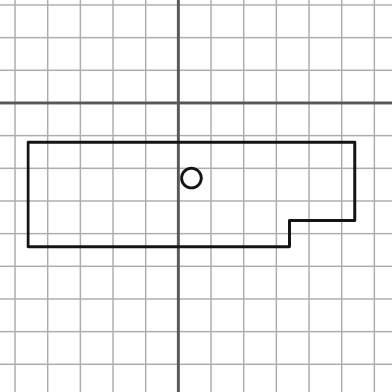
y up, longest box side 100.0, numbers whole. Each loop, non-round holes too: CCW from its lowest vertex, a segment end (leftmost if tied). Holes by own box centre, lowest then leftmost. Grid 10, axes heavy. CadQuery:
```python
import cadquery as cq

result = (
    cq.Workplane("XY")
    .moveTo(-46.0, -44.0)
    .lineTo(34.0, -44.0)
    .lineTo(34.0, -36.0)
    .lineTo(54.0, -36.0)
    .lineTo(54.0, -12.0)
    .lineTo(-46.0, -12.0)
    .close()
    .moveTo(4.0, -23.0)
    .circle(3.0)
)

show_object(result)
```